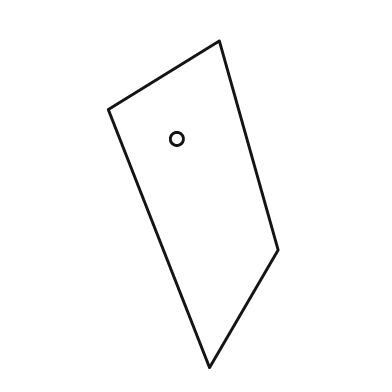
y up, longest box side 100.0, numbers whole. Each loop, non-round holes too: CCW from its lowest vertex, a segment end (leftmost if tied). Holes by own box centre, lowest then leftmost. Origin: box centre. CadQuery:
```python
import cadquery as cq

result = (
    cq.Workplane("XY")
    .moveTo(5.0, -50.0)
    .lineTo(26.0, -14.0)
    .lineTo(8.0, 50.0)
    .lineTo(-26.0, 29.0)
    .close()
    .moveTo(-5.0, 20.0)
    .circle(2.0)
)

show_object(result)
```